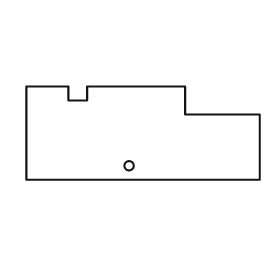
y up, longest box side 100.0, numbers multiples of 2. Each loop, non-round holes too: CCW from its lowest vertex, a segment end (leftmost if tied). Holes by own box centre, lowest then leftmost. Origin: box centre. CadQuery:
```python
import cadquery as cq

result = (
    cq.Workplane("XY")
    .moveTo(-50.0, -20.0)
    .lineTo(50.0, -20.0)
    .lineTo(50.0, 8.0)
    .lineTo(18.0, 8.0)
    .lineTo(18.0, 20.0)
    .lineTo(-24.0, 20.0)
    .lineTo(-24.0, 14.0)
    .lineTo(-32.0, 14.0)
    .lineTo(-32.0, 20.0)
    .lineTo(-50.0, 20.0)
    .close()
    .moveTo(-6.0, -14.0)
    .circle(2.0)
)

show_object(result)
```